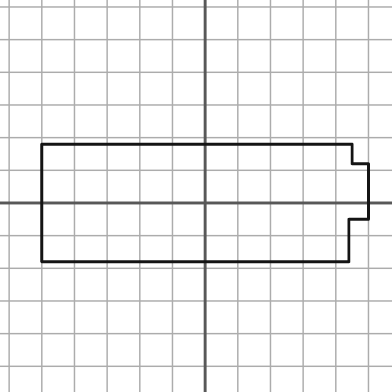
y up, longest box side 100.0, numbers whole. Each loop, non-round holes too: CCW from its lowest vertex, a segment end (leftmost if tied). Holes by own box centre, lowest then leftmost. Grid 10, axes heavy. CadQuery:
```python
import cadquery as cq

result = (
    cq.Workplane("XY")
    .moveTo(-50.0, -18.0)
    .lineTo(44.0, -18.0)
    .lineTo(44.0, -5.0)
    .lineTo(50.0, -5.0)
    .lineTo(50.0, 12.0)
    .lineTo(45.0, 12.0)
    .lineTo(45.0, 18.0)
    .lineTo(-50.0, 18.0)
    .close()
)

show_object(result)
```